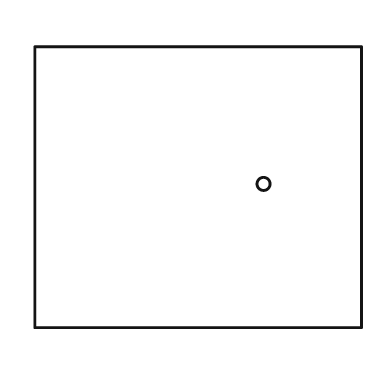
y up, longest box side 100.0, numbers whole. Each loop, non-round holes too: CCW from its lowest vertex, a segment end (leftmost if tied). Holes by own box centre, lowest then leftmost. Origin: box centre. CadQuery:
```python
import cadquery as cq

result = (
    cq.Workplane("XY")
    .moveTo(-50.0, -43.0)
    .lineTo(50.0, -43.0)
    .lineTo(50.0, 43.0)
    .lineTo(-50.0, 43.0)
    .close()
    .moveTo(20.0, 1.0)
    .circle(2.0)
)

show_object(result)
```